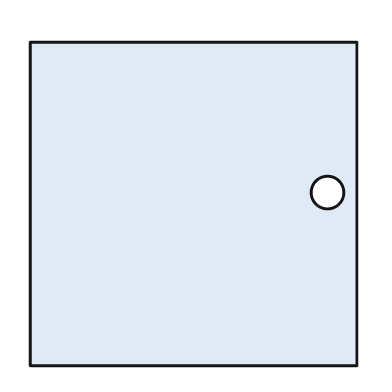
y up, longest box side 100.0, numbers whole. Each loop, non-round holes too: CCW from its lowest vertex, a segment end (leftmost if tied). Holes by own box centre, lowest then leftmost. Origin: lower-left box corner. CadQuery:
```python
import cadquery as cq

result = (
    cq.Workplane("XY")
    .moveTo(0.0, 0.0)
    .lineTo(100.0, 0.0)
    .lineTo(100.0, 99.0)
    .lineTo(0.0, 99.0)
    .close()
    .moveTo(91.0, 53.0)
    .circle(5.0)
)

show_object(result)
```